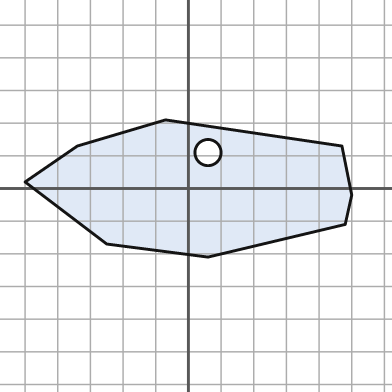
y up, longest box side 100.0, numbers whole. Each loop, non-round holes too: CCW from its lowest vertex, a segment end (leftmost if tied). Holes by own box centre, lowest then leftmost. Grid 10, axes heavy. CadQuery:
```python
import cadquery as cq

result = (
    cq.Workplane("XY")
    .moveTo(6.0, -21.0)
    .lineTo(48.0, -11.0)
    .lineTo(50.0, -2.0)
    .lineTo(47.0, 13.0)
    .lineTo(-7.0, 21.0)
    .lineTo(-34.0, 13.0)
    .lineTo(-50.0, 2.0)
    .lineTo(-25.0, -17.0)
    .close()
    .moveTo(6.0, 11.0)
    .circle(4.0)
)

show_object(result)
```